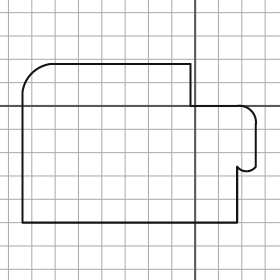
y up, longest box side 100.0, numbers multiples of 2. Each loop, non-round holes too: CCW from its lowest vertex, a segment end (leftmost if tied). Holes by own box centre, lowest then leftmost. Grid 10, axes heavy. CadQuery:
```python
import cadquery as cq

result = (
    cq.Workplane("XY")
    .moveTo(-74.0, -50.0)
    .lineTo(18.0, -50.0)
    .lineTo(18.0, -26.0)
    .threePointArc((22.0, -28.0), (26.0, -26.0))
    .lineTo(26.0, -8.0)
    .threePointArc((24.0, -2.0), (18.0, 0.0))
    .lineTo(-2.0, 0.0)
    .lineTo(-2.0, 18.0)
    .lineTo(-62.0, 18.0)
    .threePointArc((-70.0, 14.0), (-74.0, 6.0))
    .close()
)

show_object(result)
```